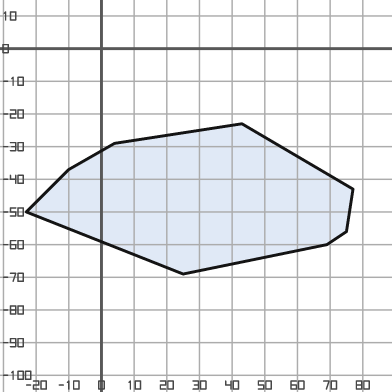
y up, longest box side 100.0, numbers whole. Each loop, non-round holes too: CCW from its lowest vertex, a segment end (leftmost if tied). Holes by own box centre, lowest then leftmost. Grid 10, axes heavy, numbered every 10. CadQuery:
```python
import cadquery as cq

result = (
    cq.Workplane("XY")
    .moveTo(25.0, -69.0)
    .lineTo(69.0, -60.0)
    .lineTo(75.0, -56.0)
    .lineTo(77.0, -43.0)
    .lineTo(43.0, -23.0)
    .lineTo(4.0, -29.0)
    .lineTo(-10.0, -37.0)
    .lineTo(-23.0, -50.0)
    .close()
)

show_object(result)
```